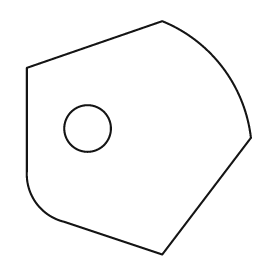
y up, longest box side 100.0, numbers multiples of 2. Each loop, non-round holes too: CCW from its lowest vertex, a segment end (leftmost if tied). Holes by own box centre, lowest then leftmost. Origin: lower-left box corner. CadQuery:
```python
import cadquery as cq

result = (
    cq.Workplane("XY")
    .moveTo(58.0, 0.0)
    .lineTo(96.0, 50.0)
    .threePointArc((84.0, 80.0), (58.0, 100.0))
    .lineTo(0.0, 80.0)
    .lineTo(0.0, 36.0)
    .threePointArc((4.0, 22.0), (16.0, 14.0))
    .close()
    .moveTo(26.0, 54.0)
    .circle(10.0)
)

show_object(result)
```